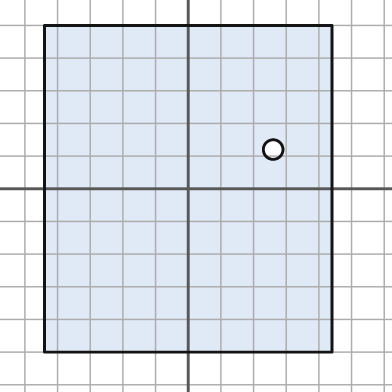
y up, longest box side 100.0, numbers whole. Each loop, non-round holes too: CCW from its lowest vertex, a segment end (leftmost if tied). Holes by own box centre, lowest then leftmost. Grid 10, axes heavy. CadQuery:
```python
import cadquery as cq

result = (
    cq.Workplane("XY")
    .moveTo(-44.0, -50.0)
    .lineTo(44.0, -50.0)
    .lineTo(44.0, 50.0)
    .lineTo(-44.0, 50.0)
    .close()
    .moveTo(26.0, 12.0)
    .circle(3.0)
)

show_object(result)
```